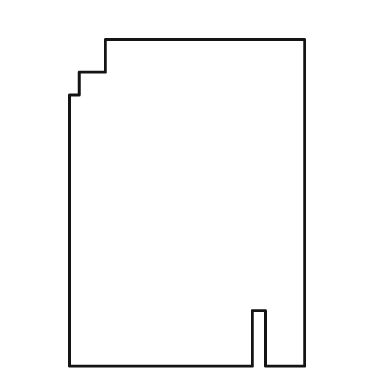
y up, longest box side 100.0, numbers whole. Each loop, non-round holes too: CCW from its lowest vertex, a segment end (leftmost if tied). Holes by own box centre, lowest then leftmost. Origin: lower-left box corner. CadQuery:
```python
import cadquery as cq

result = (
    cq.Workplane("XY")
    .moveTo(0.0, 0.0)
    .lineTo(56.0, 0.0)
    .lineTo(56.0, 17.0)
    .lineTo(60.0, 17.0)
    .lineTo(60.0, 0.0)
    .lineTo(72.0, 0.0)
    .lineTo(72.0, 100.0)
    .lineTo(11.0, 100.0)
    .lineTo(11.0, 90.0)
    .lineTo(3.0, 90.0)
    .lineTo(3.0, 83.0)
    .lineTo(0.0, 83.0)
    .close()
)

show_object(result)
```